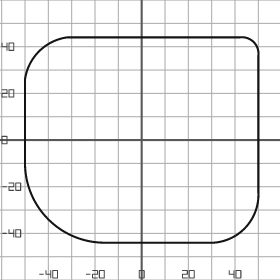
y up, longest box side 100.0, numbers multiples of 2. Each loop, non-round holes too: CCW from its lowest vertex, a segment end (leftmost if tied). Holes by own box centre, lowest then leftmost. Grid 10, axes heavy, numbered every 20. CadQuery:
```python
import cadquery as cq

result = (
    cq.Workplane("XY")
    .moveTo(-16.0, -44.0)
    .lineTo(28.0, -44.0)
    .threePointArc((44.0, -38.0), (50.0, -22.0))
    .lineTo(50.0, 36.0)
    .threePointArc((48.0, 42.0), (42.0, 44.0))
    .lineTo(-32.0, 44.0)
    .threePointArc((-44.0, 38.0), (-50.0, 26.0))
    .lineTo(-50.0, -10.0)
    .threePointArc((-40.0, -34.0), (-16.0, -44.0))
    .close()
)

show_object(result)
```